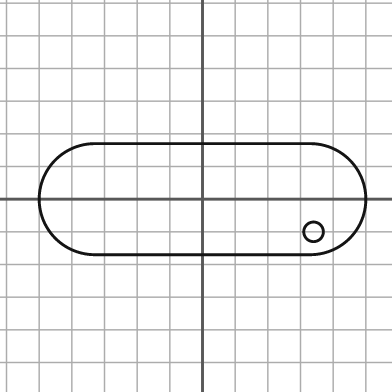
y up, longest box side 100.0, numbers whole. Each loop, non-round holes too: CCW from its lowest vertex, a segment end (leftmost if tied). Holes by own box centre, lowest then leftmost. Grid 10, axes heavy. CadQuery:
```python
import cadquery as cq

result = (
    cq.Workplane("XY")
    .moveTo(-33.0, -17.0)
    .lineTo(33.0, -17.0)
    .threePointArc((50.0, 0.0), (33.0, 17.0))
    .lineTo(-33.0, 17.0)
    .threePointArc((-50.0, 0.0), (-33.0, -17.0))
    .close()
    .moveTo(34.0, -10.0)
    .circle(3.0)
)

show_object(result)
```